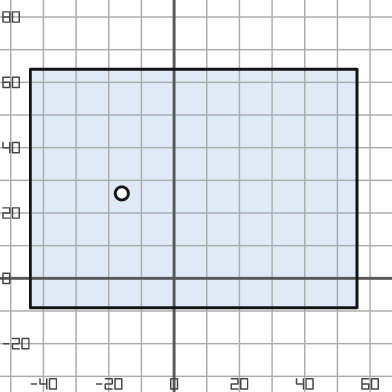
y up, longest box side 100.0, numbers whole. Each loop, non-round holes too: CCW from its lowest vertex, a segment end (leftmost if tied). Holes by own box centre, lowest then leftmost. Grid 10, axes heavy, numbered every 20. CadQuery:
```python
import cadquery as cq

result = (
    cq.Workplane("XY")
    .moveTo(-44.0, -9.0)
    .lineTo(56.0, -9.0)
    .lineTo(56.0, 64.0)
    .lineTo(-44.0, 64.0)
    .close()
    .moveTo(-16.0, 26.0)
    .circle(2.0)
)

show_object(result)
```